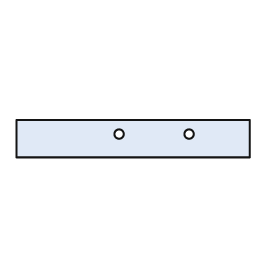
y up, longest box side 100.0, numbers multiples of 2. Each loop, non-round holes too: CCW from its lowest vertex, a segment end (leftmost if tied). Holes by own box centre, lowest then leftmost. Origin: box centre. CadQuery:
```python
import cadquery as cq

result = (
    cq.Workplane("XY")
    .moveTo(-50.0, -8.0)
    .lineTo(50.0, -8.0)
    .lineTo(50.0, 8.0)
    .lineTo(-50.0, 8.0)
    .close()
    .moveTo(-6.0, 2.0)
    .circle(2.0)
    .moveTo(24.0, 2.0)
    .circle(2.0)
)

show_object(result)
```